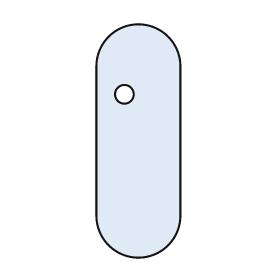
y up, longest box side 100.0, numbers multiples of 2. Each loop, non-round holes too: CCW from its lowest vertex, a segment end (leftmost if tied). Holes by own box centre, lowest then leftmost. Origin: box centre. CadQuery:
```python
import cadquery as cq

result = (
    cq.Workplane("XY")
    .moveTo(-18.0, -32.0)
    .threePointArc((0.0, -50.0), (18.0, -32.0))
    .lineTo(18.0, 32.0)
    .threePointArc((0.0, 50.0), (-18.0, 32.0))
    .close()
    .moveTo(-6.0, 20.0)
    .circle(4.0)
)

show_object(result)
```